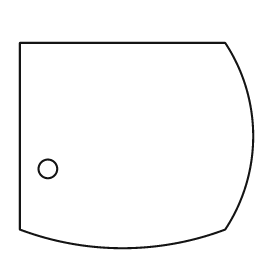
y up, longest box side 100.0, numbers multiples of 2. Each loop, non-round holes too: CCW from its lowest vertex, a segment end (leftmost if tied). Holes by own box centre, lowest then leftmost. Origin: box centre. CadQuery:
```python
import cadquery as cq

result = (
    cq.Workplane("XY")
    .moveTo(-50.0, -36.0)
    .threePointArc((-6.0, -44.0), (38.0, -36.0))
    .threePointArc((50.0, 4.0), (38.0, 44.0))
    .lineTo(-50.0, 44.0)
    .close()
    .moveTo(-38.0, -10.0)
    .circle(4.0)
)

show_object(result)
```